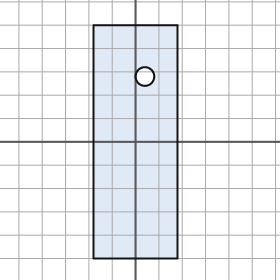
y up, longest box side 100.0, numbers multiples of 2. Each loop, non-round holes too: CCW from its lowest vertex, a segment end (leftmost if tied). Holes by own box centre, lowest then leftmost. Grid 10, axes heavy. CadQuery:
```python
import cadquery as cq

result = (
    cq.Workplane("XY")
    .moveTo(-18.0, -50.0)
    .lineTo(18.0, -50.0)
    .lineTo(18.0, 50.0)
    .lineTo(-18.0, 50.0)
    .close()
    .moveTo(4.0, 28.0)
    .circle(4.0)
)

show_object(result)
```